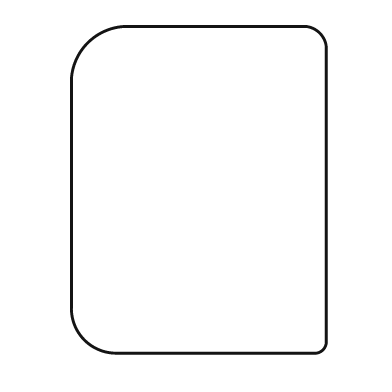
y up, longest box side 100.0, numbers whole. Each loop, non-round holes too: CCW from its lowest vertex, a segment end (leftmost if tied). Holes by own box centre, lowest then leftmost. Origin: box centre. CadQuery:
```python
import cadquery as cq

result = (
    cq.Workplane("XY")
    .moveTo(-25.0, -50.0)
    .lineTo(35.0, -50.0)
    .threePointArc((38.0, -49.0), (39.0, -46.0))
    .lineTo(39.0, 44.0)
    .threePointArc((37.0, 48.0), (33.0, 50.0))
    .lineTo(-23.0, 50.0)
    .threePointArc((-34.0, 45.0), (-39.0, 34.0))
    .lineTo(-39.0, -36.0)
    .threePointArc((-35.0, -46.0), (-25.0, -50.0))
    .close()
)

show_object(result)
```